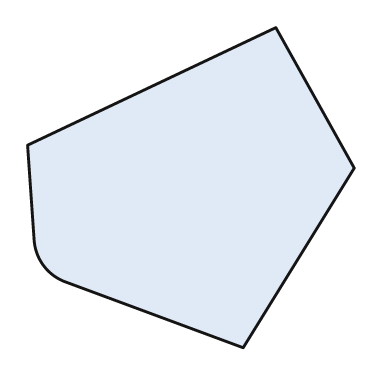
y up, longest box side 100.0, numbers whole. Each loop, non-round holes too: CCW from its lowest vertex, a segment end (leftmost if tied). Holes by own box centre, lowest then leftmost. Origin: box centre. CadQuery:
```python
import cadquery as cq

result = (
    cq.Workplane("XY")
    .moveTo(16.0, -49.0)
    .lineTo(50.0, 6.0)
    .lineTo(26.0, 49.0)
    .lineTo(-50.0, 13.0)
    .lineTo(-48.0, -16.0)
    .threePointArc((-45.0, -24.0), (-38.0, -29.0))
    .close()
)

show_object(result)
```